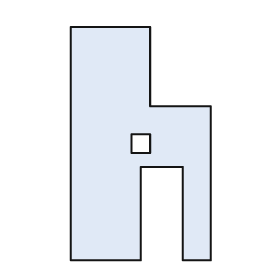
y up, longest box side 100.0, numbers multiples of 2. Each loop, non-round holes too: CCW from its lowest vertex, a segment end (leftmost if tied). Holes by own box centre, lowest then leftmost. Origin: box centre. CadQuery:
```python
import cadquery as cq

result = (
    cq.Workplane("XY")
    .moveTo(-30.0, -50.0)
    .lineTo(0.0, -50.0)
    .lineTo(0.0, -10.0)
    .lineTo(18.0, -10.0)
    .lineTo(18.0, -50.0)
    .lineTo(30.0, -50.0)
    .lineTo(30.0, 16.0)
    .lineTo(4.0, 16.0)
    .lineTo(4.0, 50.0)
    .lineTo(-30.0, 50.0)
    .close()
    .moveTo(-4.0, -4.0)
    .lineTo(4.0, -4.0)
    .lineTo(4.0, 4.0)
    .lineTo(-4.0, 4.0)
    .close()
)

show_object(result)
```